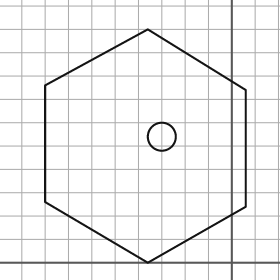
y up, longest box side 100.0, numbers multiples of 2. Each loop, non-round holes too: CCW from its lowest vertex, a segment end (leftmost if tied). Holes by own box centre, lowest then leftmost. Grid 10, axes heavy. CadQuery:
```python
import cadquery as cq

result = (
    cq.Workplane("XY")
    .moveTo(-36.0, 0.0)
    .lineTo(6.0, 24.0)
    .lineTo(6.0, 74.0)
    .lineTo(-36.0, 100.0)
    .lineTo(-80.0, 76.0)
    .lineTo(-80.0, 26.0)
    .close()
    .moveTo(-30.0, 54.0)
    .circle(6.0)
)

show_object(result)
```